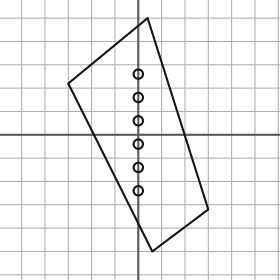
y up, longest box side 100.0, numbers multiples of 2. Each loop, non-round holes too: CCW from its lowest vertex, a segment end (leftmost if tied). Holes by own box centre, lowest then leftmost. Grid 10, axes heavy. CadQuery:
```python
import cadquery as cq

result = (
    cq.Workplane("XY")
    .moveTo(6.0, -50.0)
    .lineTo(30.0, -32.0)
    .lineTo(4.0, 50.0)
    .lineTo(-30.0, 22.0)
    .close()
    .moveTo(0.0, -24.0)
    .circle(2.0)
    .moveTo(0.0, -14.0)
    .circle(2.0)
    .moveTo(0.0, -4.0)
    .circle(2.0)
    .moveTo(0.0, 6.0)
    .circle(2.0)
    .moveTo(0.0, 16.0)
    .circle(2.0)
    .moveTo(0.0, 26.0)
    .circle(2.0)
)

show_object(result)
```